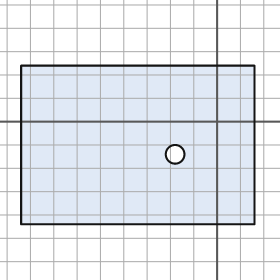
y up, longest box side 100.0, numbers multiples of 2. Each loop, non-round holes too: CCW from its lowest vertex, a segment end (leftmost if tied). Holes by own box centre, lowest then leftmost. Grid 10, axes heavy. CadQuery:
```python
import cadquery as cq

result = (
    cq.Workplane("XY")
    .moveTo(-84.0, -44.0)
    .lineTo(16.0, -44.0)
    .lineTo(16.0, 24.0)
    .lineTo(-84.0, 24.0)
    .close()
    .moveTo(-18.0, -14.0)
    .circle(4.0)
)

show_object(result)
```